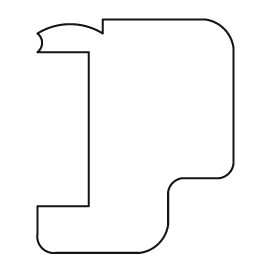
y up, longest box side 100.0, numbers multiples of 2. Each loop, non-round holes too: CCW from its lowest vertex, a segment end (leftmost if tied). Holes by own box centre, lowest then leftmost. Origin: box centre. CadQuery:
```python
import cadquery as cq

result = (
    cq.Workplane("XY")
    .moveTo(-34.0, -50.0)
    .lineTo(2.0, -50.0)
    .threePointArc((10.0, -46.0), (14.0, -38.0))
    .lineTo(14.0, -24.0)
    .threePointArc((16.0, -20.0), (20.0, -18.0))
    .lineTo(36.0, -18.0)
    .threePointArc((40.0, -16.0), (42.0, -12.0))
    .lineTo(42.0, 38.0)
    .threePointArc((38.0, 46.0), (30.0, 50.0))
    .lineTo(-14.0, 50.0)
    .lineTo(-14.0, 44.0)
    .threePointArc((-28.0, 48.0), (-42.0, 44.0))
    .threePointArc((-40.0, 40.0), (-42.0, 36.0))
    .lineTo(-20.0, 36.0)
    .lineTo(-20.0, -30.0)
    .lineTo(-42.0, -30.0)
    .lineTo(-42.0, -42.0)
    .threePointArc((-40.0, -48.0), (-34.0, -50.0))
    .close()
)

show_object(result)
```